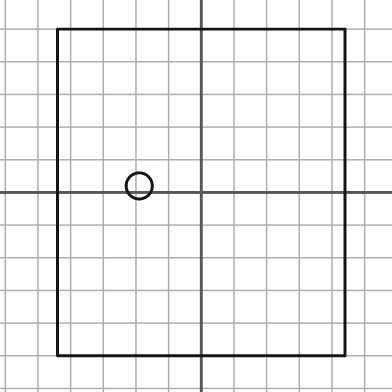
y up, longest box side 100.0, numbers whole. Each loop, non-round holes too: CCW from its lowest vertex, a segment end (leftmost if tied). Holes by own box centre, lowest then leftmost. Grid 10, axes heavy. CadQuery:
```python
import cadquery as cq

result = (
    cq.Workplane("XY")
    .moveTo(-44.0, -50.0)
    .lineTo(44.0, -50.0)
    .lineTo(44.0, 50.0)
    .lineTo(-44.0, 50.0)
    .close()
    .moveTo(-19.0, 2.0)
    .circle(4.0)
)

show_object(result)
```